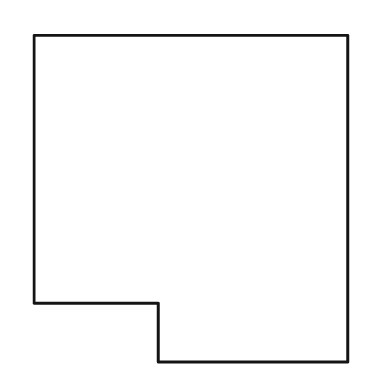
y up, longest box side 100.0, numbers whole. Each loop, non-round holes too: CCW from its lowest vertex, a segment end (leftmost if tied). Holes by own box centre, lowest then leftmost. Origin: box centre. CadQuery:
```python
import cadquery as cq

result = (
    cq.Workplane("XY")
    .moveTo(-10.0, -50.0)
    .lineTo(48.0, -50.0)
    .lineTo(48.0, 50.0)
    .lineTo(-48.0, 50.0)
    .lineTo(-48.0, -32.0)
    .lineTo(-10.0, -32.0)
    .close()
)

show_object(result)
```